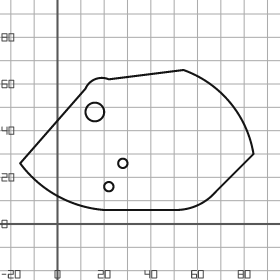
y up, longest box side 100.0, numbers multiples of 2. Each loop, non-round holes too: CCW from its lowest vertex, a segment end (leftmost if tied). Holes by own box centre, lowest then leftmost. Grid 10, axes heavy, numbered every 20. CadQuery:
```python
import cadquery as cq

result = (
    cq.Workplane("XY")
    .moveTo(20.0, 6.0)
    .lineTo(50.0, 6.0)
    .threePointArc((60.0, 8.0), (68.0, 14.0))
    .lineTo(84.0, 30.0)
    .threePointArc((74.0, 52.0), (54.0, 66.0))
    .lineTo(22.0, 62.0)
    .threePointArc((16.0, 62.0), (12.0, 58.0))
    .lineTo(-16.0, 26.0)
    .threePointArc((0.0, 12.0), (20.0, 6.0))
    .close()
    .moveTo(22.0, 16.0)
    .circle(2.0)
    .moveTo(28.0, 26.0)
    .circle(2.0)
    .moveTo(16.0, 48.0)
    .circle(4.0)
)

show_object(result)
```